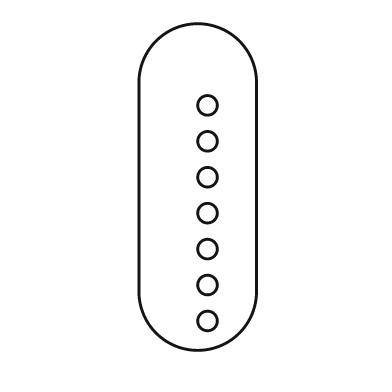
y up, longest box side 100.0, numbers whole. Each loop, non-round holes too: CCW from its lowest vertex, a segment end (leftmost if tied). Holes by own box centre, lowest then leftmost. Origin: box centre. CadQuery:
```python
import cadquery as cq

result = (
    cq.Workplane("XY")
    .moveTo(-18.0, -32.0)
    .threePointArc((0.0, -50.0), (18.0, -32.0))
    .lineTo(18.0, 32.0)
    .threePointArc((0.0, 50.0), (-18.0, 32.0))
    .close()
    .moveTo(3.0, -41.0)
    .circle(3.0)
    .moveTo(3.0, -30.0)
    .circle(3.0)
    .moveTo(3.0, -19.0)
    .circle(3.0)
    .moveTo(3.0, -8.0)
    .circle(3.0)
    .moveTo(3.0, 3.0)
    .circle(3.0)
    .moveTo(3.0, 14.0)
    .circle(3.0)
    .moveTo(3.0, 25.0)
    .circle(3.0)
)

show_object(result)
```